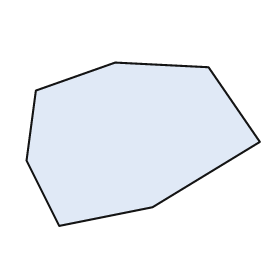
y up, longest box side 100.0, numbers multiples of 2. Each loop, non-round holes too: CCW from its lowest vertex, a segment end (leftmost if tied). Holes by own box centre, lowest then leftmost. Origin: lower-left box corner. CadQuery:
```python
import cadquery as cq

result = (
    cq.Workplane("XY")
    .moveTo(14.0, 0.0)
    .lineTo(54.0, 8.0)
    .lineTo(100.0, 36.0)
    .lineTo(78.0, 68.0)
    .lineTo(38.0, 70.0)
    .lineTo(4.0, 58.0)
    .lineTo(0.0, 28.0)
    .close()
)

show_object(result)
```